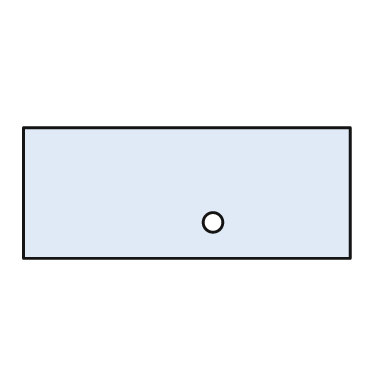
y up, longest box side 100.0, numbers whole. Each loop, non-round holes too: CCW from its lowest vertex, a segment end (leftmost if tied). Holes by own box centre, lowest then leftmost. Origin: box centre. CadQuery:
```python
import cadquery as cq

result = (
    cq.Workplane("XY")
    .moveTo(-50.0, -20.0)
    .lineTo(50.0, -20.0)
    .lineTo(50.0, 20.0)
    .lineTo(-50.0, 20.0)
    .close()
    .moveTo(8.0, -9.0)
    .circle(3.0)
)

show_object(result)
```